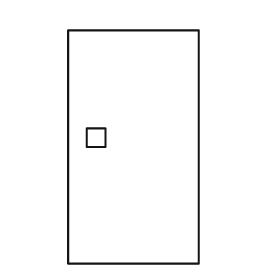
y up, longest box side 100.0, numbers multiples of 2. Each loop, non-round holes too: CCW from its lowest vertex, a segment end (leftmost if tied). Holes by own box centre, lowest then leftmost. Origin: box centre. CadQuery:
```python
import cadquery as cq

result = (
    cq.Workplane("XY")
    .moveTo(-28.0, -50.0)
    .lineTo(28.0, -50.0)
    .lineTo(28.0, 50.0)
    .lineTo(-28.0, 50.0)
    .close()
    .moveTo(-20.0, 0.0)
    .lineTo(-12.0, 0.0)
    .lineTo(-12.0, 8.0)
    .lineTo(-20.0, 8.0)
    .close()
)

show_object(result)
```